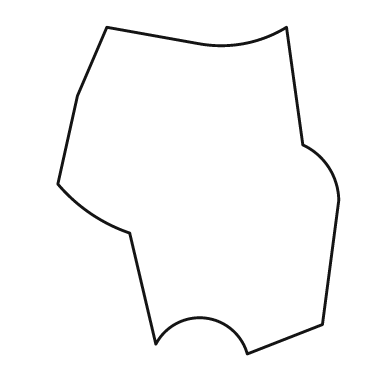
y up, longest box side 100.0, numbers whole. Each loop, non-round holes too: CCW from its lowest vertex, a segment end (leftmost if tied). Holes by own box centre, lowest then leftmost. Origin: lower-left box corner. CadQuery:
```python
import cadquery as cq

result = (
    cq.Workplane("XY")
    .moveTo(58.0, 0.0)
    .lineTo(81.0, 9.0)
    .lineTo(86.0, 47.0)
    .threePointArc((83.0, 57.0), (75.0, 64.0))
    .lineTo(70.0, 100.0)
    .threePointArc((57.0, 95.0), (43.0, 95.0))
    .lineTo(15.0, 100.0)
    .lineTo(6.0, 79.0)
    .lineTo(0.0, 52.0)
    .threePointArc((10.0, 43.0), (22.0, 37.0))
    .lineTo(30.0, 3.0)
    .threePointArc((45.0, 11.0), (58.0, 0.0))
    .close()
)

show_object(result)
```